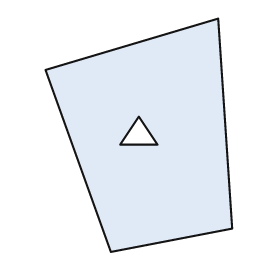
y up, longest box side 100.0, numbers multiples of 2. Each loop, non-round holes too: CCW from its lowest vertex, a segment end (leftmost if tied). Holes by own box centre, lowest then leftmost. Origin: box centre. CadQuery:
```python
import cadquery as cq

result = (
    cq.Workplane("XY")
    .moveTo(-12.0, -50.0)
    .lineTo(40.0, -40.0)
    .lineTo(34.0, 50.0)
    .lineTo(-40.0, 28.0)
    .close()
    .moveTo(-8.0, -4.0)
    .lineTo(8.0, -4.0)
    .lineTo(0.0, 8.0)
    .close()
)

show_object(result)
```